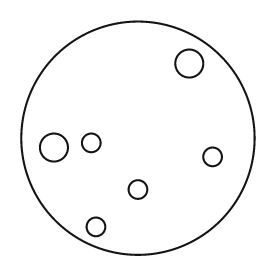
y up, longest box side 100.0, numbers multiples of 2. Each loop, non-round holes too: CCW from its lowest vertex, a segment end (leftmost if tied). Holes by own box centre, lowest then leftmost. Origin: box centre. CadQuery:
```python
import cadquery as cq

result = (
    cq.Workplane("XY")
    .moveTo(0.0, 0.0)
    .circle(50.0)
    .moveTo(-18.0, -38.0)
    .circle(4.0)
    .moveTo(0.0, -22.0)
    .circle(4.0)
    .moveTo(32.0, -8.0)
    .circle(4.0)
    .moveTo(-36.0, -4.0)
    .circle(6.0)
    .moveTo(-20.0, -2.0)
    .circle(4.0)
    .moveTo(22.0, 32.0)
    .circle(6.0)
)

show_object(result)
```